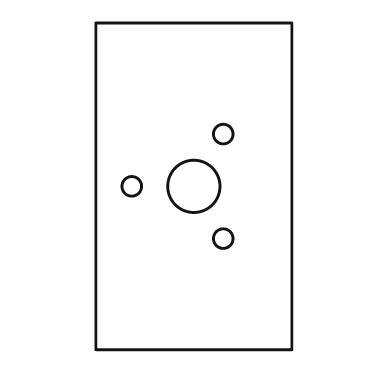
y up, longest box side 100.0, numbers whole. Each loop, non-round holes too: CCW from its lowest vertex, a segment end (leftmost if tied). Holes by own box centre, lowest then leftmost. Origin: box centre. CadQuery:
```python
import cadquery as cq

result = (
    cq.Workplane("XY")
    .moveTo(-30.0, -50.0)
    .lineTo(30.0, -50.0)
    .lineTo(30.0, 50.0)
    .lineTo(-30.0, 50.0)
    .close()
    .moveTo(9.0, -16.0)
    .circle(3.0)
    .moveTo(-19.0, 0.0)
    .circle(3.0)
    .moveTo(0.0, 0.0)
    .circle(8.0)
    .moveTo(9.0, 16.0)
    .circle(3.0)
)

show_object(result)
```